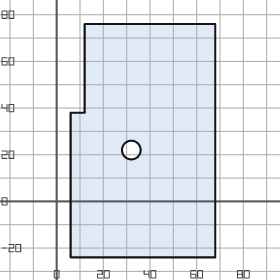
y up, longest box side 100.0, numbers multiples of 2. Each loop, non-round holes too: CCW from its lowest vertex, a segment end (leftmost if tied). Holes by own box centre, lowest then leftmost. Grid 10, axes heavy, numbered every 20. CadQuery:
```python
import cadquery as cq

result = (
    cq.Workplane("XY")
    .moveTo(6.0, -24.0)
    .lineTo(68.0, -24.0)
    .lineTo(68.0, 76.0)
    .lineTo(12.0, 76.0)
    .lineTo(12.0, 38.0)
    .lineTo(6.0, 38.0)
    .close()
    .moveTo(32.0, 22.0)
    .circle(4.0)
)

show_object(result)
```